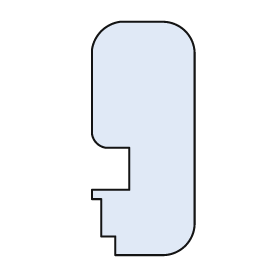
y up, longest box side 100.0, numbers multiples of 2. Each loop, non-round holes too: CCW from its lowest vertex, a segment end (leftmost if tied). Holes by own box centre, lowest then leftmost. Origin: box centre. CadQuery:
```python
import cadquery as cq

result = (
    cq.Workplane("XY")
    .moveTo(-12.0, -50.0)
    .lineTo(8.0, -50.0)
    .threePointArc((18.0, -46.0), (22.0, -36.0))
    .lineTo(22.0, 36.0)
    .threePointArc((18.0, 46.0), (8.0, 50.0))
    .lineTo(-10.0, 50.0)
    .threePointArc((-18.0, 46.0), (-22.0, 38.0))
    .lineTo(-22.0, 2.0)
    .threePointArc((-20.0, -2.0), (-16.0, -4.0))
    .lineTo(-6.0, -4.0)
    .lineTo(-6.0, -22.0)
    .lineTo(-22.0, -22.0)
    .lineTo(-22.0, -26.0)
    .lineTo(-18.0, -26.0)
    .lineTo(-18.0, -42.0)
    .lineTo(-12.0, -42.0)
    .close()
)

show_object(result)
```